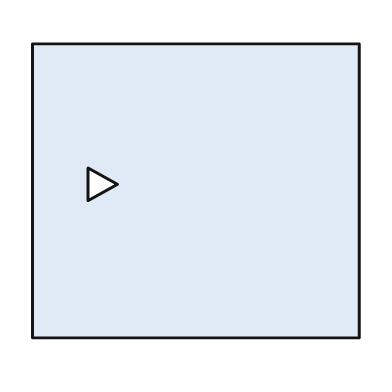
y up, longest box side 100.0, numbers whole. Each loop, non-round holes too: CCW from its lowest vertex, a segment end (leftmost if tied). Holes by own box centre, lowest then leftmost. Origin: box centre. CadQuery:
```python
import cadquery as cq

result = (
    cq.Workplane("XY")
    .moveTo(-50.0, -45.0)
    .lineTo(50.0, -45.0)
    .lineTo(50.0, 45.0)
    .lineTo(-50.0, 45.0)
    .close()
    .moveTo(-33.0, -3.0)
    .lineTo(-24.0, 2.0)
    .lineTo(-33.0, 7.0)
    .close()
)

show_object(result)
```